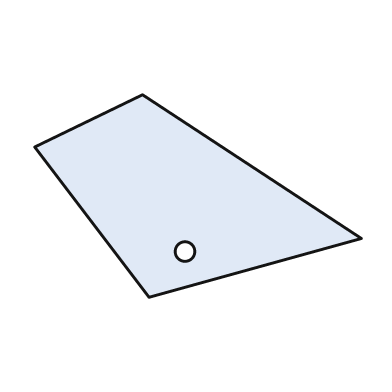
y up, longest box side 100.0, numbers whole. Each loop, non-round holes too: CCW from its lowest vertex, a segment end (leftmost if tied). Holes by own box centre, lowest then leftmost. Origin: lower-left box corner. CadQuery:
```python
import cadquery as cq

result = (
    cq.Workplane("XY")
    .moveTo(35.0, 0.0)
    .lineTo(100.0, 18.0)
    .lineTo(33.0, 62.0)
    .lineTo(0.0, 46.0)
    .close()
    .moveTo(46.0, 14.0)
    .circle(3.0)
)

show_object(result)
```